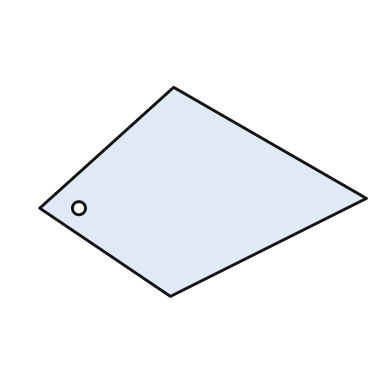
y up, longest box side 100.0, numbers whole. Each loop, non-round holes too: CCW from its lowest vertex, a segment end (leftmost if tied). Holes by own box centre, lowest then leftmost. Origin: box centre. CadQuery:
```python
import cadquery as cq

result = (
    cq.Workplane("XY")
    .moveTo(-10.0, -32.0)
    .lineTo(50.0, -2.0)
    .lineTo(-9.0, 32.0)
    .lineTo(-50.0, -5.0)
    .close()
    .moveTo(-38.0, -5.0)
    .circle(2.0)
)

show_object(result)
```